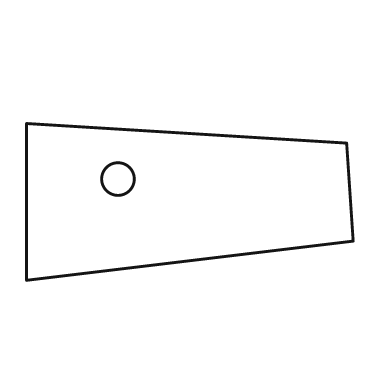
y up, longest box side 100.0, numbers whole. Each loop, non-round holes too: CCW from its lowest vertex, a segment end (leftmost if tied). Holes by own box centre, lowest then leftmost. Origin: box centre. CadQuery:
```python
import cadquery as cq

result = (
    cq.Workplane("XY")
    .moveTo(-50.0, -24.0)
    .lineTo(50.0, -12.0)
    .lineTo(48.0, 18.0)
    .lineTo(-50.0, 24.0)
    .close()
    .moveTo(-22.0, 7.0)
    .circle(5.0)
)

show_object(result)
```